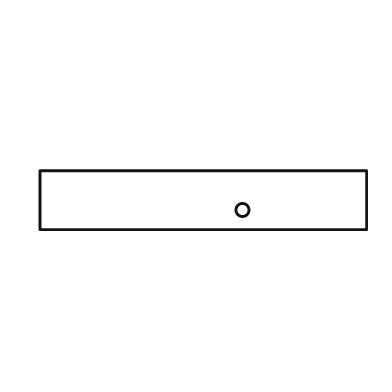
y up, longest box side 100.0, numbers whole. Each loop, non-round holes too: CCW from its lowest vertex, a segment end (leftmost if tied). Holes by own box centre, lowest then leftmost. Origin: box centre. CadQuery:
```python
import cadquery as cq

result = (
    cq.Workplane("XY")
    .moveTo(-50.0, -9.0)
    .lineTo(50.0, -9.0)
    .lineTo(50.0, 9.0)
    .lineTo(-50.0, 9.0)
    .close()
    .moveTo(12.0, -3.0)
    .circle(2.0)
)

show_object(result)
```